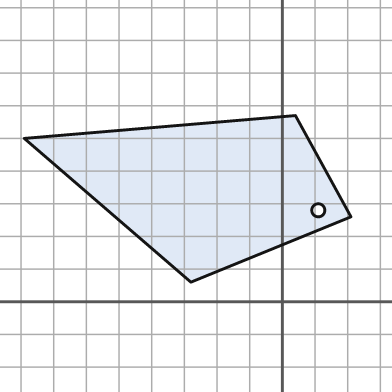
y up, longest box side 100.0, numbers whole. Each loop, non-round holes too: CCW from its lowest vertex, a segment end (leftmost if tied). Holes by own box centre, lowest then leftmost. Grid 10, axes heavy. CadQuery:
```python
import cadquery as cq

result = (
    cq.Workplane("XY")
    .moveTo(-28.0, 6.0)
    .lineTo(21.0, 26.0)
    .lineTo(4.0, 57.0)
    .lineTo(-79.0, 50.0)
    .close()
    .moveTo(11.0, 28.0)
    .circle(2.0)
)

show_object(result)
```